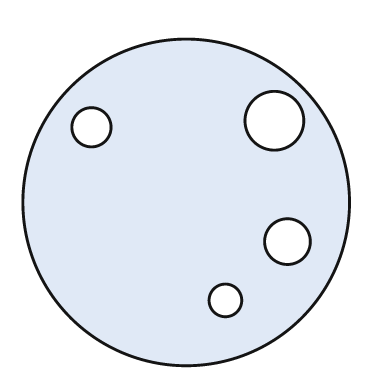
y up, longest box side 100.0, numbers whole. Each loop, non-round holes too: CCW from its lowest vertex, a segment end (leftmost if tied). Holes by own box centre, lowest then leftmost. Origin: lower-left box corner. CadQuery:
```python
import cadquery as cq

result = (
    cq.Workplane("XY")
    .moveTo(50.0, 50.0)
    .circle(50.0)
    .moveTo(62.0, 20.0)
    .circle(5.0)
    .moveTo(81.0, 38.0)
    .circle(7.0)
    .moveTo(21.0, 73.0)
    .circle(6.0)
    .moveTo(77.0, 75.0)
    .circle(9.0)
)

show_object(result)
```